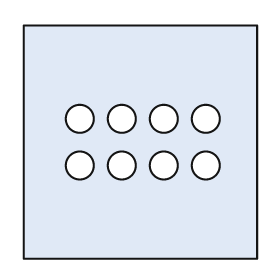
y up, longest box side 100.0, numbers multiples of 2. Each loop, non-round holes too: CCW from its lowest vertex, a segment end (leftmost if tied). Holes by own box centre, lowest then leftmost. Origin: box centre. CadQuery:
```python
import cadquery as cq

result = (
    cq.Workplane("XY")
    .moveTo(-50.0, -50.0)
    .lineTo(50.0, -50.0)
    .lineTo(50.0, 50.0)
    .lineTo(-50.0, 50.0)
    .close()
    .moveTo(-26.0, -10.0)
    .circle(6.0)
    .moveTo(-8.0, -10.0)
    .circle(6.0)
    .moveTo(10.0, -10.0)
    .circle(6.0)
    .moveTo(28.0, -10.0)
    .circle(6.0)
    .moveTo(-26.0, 10.0)
    .circle(6.0)
    .moveTo(-8.0, 10.0)
    .circle(6.0)
    .moveTo(10.0, 10.0)
    .circle(6.0)
    .moveTo(28.0, 10.0)
    .circle(6.0)
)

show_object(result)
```